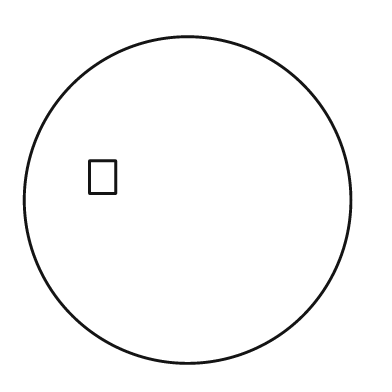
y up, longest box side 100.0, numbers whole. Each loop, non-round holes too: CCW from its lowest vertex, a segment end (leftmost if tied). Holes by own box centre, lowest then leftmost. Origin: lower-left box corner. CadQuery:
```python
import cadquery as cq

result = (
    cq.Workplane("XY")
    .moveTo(50.0, 50.0)
    .circle(50.0)
    .moveTo(20.0, 52.0)
    .lineTo(28.0, 52.0)
    .lineTo(28.0, 62.0)
    .lineTo(20.0, 62.0)
    .close()
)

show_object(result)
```